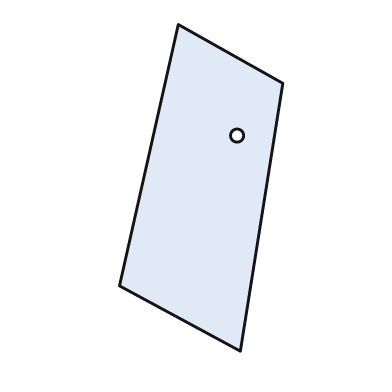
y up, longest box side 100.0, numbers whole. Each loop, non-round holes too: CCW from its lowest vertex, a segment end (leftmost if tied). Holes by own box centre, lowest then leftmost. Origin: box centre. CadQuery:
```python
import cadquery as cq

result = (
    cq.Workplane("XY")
    .moveTo(12.0, -50.0)
    .lineTo(25.0, 32.0)
    .lineTo(-7.0, 50.0)
    .lineTo(-25.0, -30.0)
    .close()
    .moveTo(11.0, 16.0)
    .circle(2.0)
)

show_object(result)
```